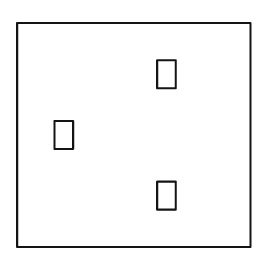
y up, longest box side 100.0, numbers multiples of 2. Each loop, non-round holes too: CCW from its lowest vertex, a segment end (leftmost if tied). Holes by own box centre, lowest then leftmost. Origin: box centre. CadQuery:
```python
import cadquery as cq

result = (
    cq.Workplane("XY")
    .moveTo(-50.0, -48.0)
    .lineTo(50.0, -48.0)
    .lineTo(50.0, 48.0)
    .lineTo(-50.0, 48.0)
    .close()
    .moveTo(10.0, -32.0)
    .lineTo(18.0, -32.0)
    .lineTo(18.0, -20.0)
    .lineTo(10.0, -20.0)
    .close()
    .moveTo(-34.0, -6.0)
    .lineTo(-26.0, -6.0)
    .lineTo(-26.0, 6.0)
    .lineTo(-34.0, 6.0)
    .close()
    .moveTo(10.0, 20.0)
    .lineTo(18.0, 20.0)
    .lineTo(18.0, 32.0)
    .lineTo(10.0, 32.0)
    .close()
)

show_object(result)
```